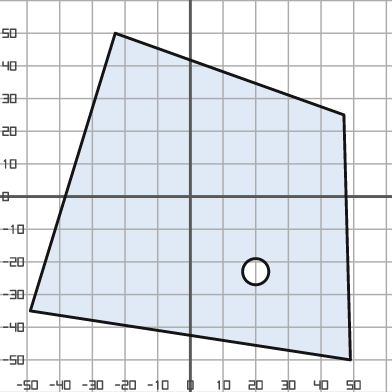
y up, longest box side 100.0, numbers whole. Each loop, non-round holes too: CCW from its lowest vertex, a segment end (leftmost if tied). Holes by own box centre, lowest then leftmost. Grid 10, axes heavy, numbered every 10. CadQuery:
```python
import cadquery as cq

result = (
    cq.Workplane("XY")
    .moveTo(49.0, -50.0)
    .lineTo(47.0, 25.0)
    .lineTo(-23.0, 50.0)
    .lineTo(-49.0, -35.0)
    .close()
    .moveTo(20.0, -23.0)
    .circle(4.0)
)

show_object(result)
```